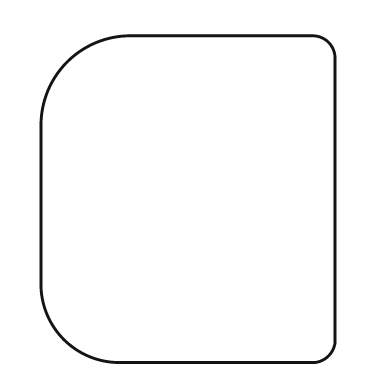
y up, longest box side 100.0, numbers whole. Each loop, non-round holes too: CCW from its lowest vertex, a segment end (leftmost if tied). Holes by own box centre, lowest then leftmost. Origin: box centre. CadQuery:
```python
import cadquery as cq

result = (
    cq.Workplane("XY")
    .moveTo(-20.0, -50.0)
    .lineTo(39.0, -50.0)
    .threePointArc((43.0, -48.0), (45.0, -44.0))
    .lineTo(45.0, 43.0)
    .threePointArc((43.0, 48.0), (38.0, 50.0))
    .lineTo(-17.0, 50.0)
    .threePointArc((-37.0, 42.0), (-45.0, 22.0))
    .lineTo(-45.0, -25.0)
    .threePointArc((-38.0, -43.0), (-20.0, -50.0))
    .close()
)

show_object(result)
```